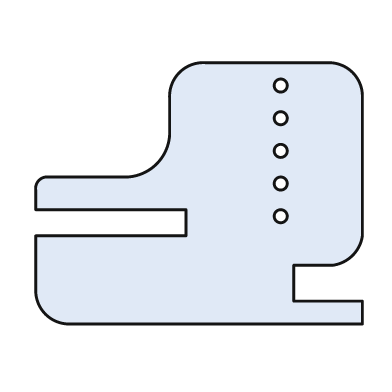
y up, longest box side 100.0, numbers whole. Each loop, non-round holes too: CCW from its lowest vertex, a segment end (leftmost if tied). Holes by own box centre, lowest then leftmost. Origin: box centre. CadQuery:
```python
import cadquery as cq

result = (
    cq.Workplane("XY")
    .moveTo(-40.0, -40.0)
    .lineTo(50.0, -40.0)
    .lineTo(50.0, -33.0)
    .lineTo(29.0, -33.0)
    .lineTo(29.0, -22.0)
    .lineTo(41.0, -22.0)
    .threePointArc((47.0, -19.0), (50.0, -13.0))
    .lineTo(50.0, 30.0)
    .threePointArc((47.0, 37.0), (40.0, 40.0))
    .lineTo(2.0, 40.0)
    .threePointArc((-6.0, 37.0), (-9.0, 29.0))
    .lineTo(-9.0, 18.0)
    .threePointArc((-13.0, 9.0), (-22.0, 5.0))
    .lineTo(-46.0, 5.0)
    .threePointArc((-49.0, 4.0), (-50.0, 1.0))
    .lineTo(-50.0, -5.0)
    .lineTo(-4.0, -5.0)
    .lineTo(-4.0, -13.0)
    .lineTo(-50.0, -13.0)
    .lineTo(-50.0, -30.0)
    .threePointArc((-47.0, -37.0), (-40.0, -40.0))
    .close()
    .moveTo(25.0, -7.0)
    .circle(2.0)
    .moveTo(25.0, 3.0)
    .circle(2.0)
    .moveTo(25.0, 13.0)
    .circle(2.0)
    .moveTo(25.0, 23.0)
    .circle(2.0)
    .moveTo(25.0, 33.0)
    .circle(2.0)
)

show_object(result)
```